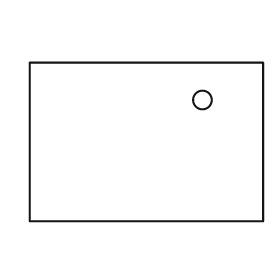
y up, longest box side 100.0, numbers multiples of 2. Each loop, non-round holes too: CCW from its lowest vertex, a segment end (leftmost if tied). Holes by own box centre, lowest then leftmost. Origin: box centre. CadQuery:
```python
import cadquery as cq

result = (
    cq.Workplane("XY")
    .moveTo(-50.0, -34.0)
    .lineTo(50.0, -34.0)
    .lineTo(50.0, 34.0)
    .lineTo(-50.0, 34.0)
    .close()
    .moveTo(24.0, 18.0)
    .circle(4.0)
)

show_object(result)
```